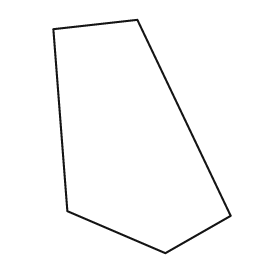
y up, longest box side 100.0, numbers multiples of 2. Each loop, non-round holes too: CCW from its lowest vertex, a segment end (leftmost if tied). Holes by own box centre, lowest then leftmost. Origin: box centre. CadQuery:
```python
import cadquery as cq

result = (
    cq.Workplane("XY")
    .moveTo(10.0, -50.0)
    .lineTo(38.0, -34.0)
    .lineTo(-2.0, 50.0)
    .lineTo(-38.0, 46.0)
    .lineTo(-32.0, -32.0)
    .close()
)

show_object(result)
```